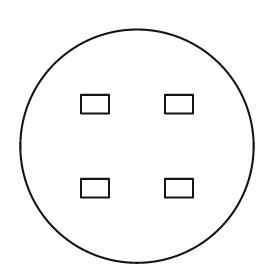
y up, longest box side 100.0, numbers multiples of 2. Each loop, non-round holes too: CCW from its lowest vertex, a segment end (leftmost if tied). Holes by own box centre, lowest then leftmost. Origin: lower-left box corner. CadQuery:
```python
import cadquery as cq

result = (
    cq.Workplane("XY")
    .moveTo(50.0, 50.0)
    .circle(50.0)
    .moveTo(26.0, 28.0)
    .lineTo(38.0, 28.0)
    .lineTo(38.0, 36.0)
    .lineTo(26.0, 36.0)
    .close()
    .moveTo(62.0, 28.0)
    .lineTo(74.0, 28.0)
    .lineTo(74.0, 36.0)
    .lineTo(62.0, 36.0)
    .close()
    .moveTo(26.0, 64.0)
    .lineTo(38.0, 64.0)
    .lineTo(38.0, 72.0)
    .lineTo(26.0, 72.0)
    .close()
    .moveTo(62.0, 64.0)
    .lineTo(74.0, 64.0)
    .lineTo(74.0, 72.0)
    .lineTo(62.0, 72.0)
    .close()
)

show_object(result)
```